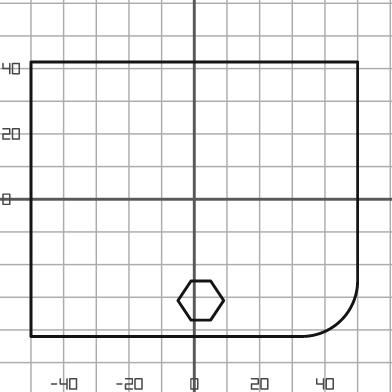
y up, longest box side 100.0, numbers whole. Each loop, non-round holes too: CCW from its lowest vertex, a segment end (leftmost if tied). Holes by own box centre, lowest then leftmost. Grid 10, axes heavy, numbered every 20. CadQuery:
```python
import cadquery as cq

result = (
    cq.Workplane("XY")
    .moveTo(-50.0, -42.0)
    .lineTo(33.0, -42.0)
    .threePointArc((45.0, -37.0), (50.0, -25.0))
    .lineTo(50.0, 42.0)
    .lineTo(-50.0, 42.0)
    .close()
    .moveTo(-1.0, -37.0)
    .lineTo(5.0, -37.0)
    .lineTo(9.0, -31.0)
    .lineTo(5.0, -25.0)
    .lineTo(-1.0, -25.0)
    .lineTo(-5.0, -31.0)
    .close()
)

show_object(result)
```